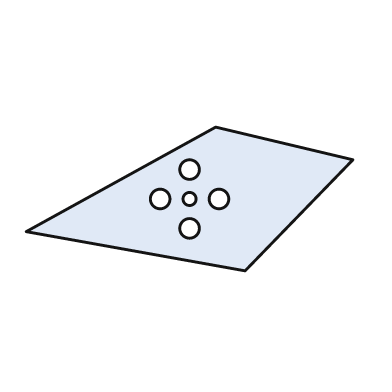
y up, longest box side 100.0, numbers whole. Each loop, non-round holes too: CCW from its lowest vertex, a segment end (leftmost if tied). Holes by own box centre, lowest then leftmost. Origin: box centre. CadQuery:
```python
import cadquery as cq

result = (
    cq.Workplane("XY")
    .moveTo(17.0, -22.0)
    .lineTo(50.0, 12.0)
    .lineTo(8.0, 22.0)
    .lineTo(-50.0, -10.0)
    .close()
    .moveTo(0.0, -9.0)
    .circle(3.0)
    .moveTo(-9.0, 0.0)
    .circle(3.0)
    .moveTo(0.0, 0.0)
    .circle(2.0)
    .moveTo(9.0, 0.0)
    .circle(3.0)
    .moveTo(0.0, 9.0)
    .circle(3.0)
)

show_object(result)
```